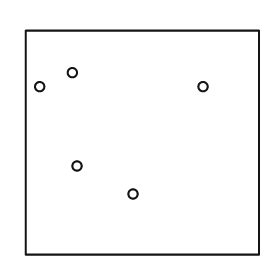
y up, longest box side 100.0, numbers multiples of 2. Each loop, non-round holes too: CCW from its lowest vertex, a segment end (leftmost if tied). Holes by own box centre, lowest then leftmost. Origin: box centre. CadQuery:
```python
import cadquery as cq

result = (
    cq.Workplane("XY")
    .moveTo(-50.0, -48.0)
    .lineTo(50.0, -48.0)
    .lineTo(50.0, 48.0)
    .lineTo(-50.0, 48.0)
    .close()
    .moveTo(-4.0, -22.0)
    .circle(2.0)
    .moveTo(-28.0, -10.0)
    .circle(2.0)
    .moveTo(-44.0, 24.0)
    .circle(2.0)
    .moveTo(26.0, 24.0)
    .circle(2.0)
    .moveTo(-30.0, 30.0)
    .circle(2.0)
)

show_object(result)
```